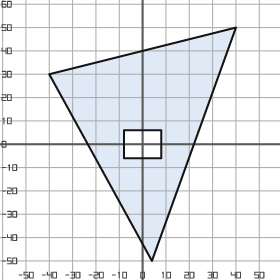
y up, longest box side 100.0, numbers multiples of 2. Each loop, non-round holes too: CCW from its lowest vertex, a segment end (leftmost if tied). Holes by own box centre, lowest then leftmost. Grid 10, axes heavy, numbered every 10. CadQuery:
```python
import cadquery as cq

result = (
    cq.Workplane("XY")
    .moveTo(4.0, -50.0)
    .lineTo(40.0, 50.0)
    .lineTo(-40.0, 30.0)
    .close()
    .moveTo(-8.0, -6.0)
    .lineTo(8.0, -6.0)
    .lineTo(8.0, 6.0)
    .lineTo(-8.0, 6.0)
    .close()
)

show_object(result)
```